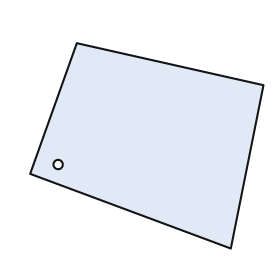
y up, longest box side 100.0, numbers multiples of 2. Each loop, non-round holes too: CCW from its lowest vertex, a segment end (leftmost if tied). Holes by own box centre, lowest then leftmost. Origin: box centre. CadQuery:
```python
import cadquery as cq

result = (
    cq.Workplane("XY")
    .moveTo(36.0, -44.0)
    .lineTo(50.0, 26.0)
    .lineTo(-30.0, 44.0)
    .lineTo(-50.0, -12.0)
    .close()
    .moveTo(-38.0, -8.0)
    .circle(2.0)
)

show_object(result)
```